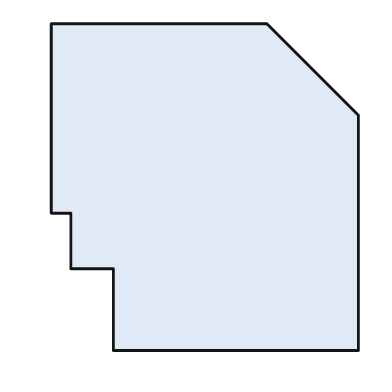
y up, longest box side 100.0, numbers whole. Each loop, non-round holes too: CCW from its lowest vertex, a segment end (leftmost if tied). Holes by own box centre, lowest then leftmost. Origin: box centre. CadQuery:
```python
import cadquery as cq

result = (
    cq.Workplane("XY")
    .moveTo(-28.0, -50.0)
    .lineTo(47.0, -50.0)
    .lineTo(47.0, 22.0)
    .lineTo(19.0, 50.0)
    .lineTo(-47.0, 50.0)
    .lineTo(-47.0, -8.0)
    .lineTo(-41.0, -8.0)
    .lineTo(-41.0, -25.0)
    .lineTo(-28.0, -25.0)
    .close()
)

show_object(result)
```